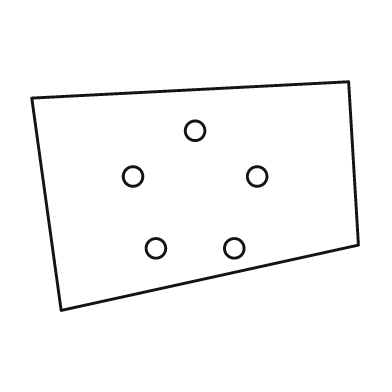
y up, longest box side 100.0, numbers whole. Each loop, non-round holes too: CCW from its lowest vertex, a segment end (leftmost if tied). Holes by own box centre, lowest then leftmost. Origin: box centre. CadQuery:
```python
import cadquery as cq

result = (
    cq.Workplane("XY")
    .moveTo(-41.0, -35.0)
    .lineTo(50.0, -15.0)
    .lineTo(47.0, 35.0)
    .lineTo(-50.0, 30.0)
    .close()
    .moveTo(-12.0, -16.0)
    .circle(3.0)
    .moveTo(12.0, -16.0)
    .circle(3.0)
    .moveTo(-19.0, 6.0)
    .circle(3.0)
    .moveTo(19.0, 6.0)
    .circle(3.0)
    .moveTo(0.0, 20.0)
    .circle(3.0)
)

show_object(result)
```